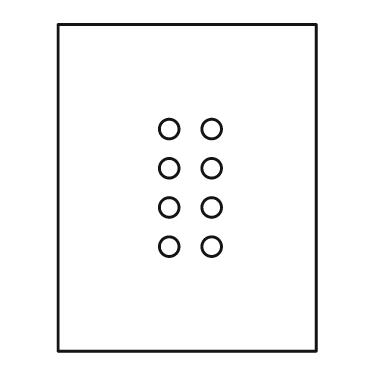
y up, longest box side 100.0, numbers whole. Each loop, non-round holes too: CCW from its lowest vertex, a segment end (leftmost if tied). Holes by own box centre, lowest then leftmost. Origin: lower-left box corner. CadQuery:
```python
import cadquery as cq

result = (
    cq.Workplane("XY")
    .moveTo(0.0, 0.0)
    .lineTo(79.0, 0.0)
    .lineTo(79.0, 100.0)
    .lineTo(0.0, 100.0)
    .close()
    .moveTo(34.0, 32.0)
    .circle(3.0)
    .moveTo(47.0, 32.0)
    .circle(3.0)
    .moveTo(34.0, 44.0)
    .circle(3.0)
    .moveTo(47.0, 44.0)
    .circle(3.0)
    .moveTo(34.0, 56.0)
    .circle(3.0)
    .moveTo(47.0, 56.0)
    .circle(3.0)
    .moveTo(34.0, 68.0)
    .circle(3.0)
    .moveTo(47.0, 68.0)
    .circle(3.0)
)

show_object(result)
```